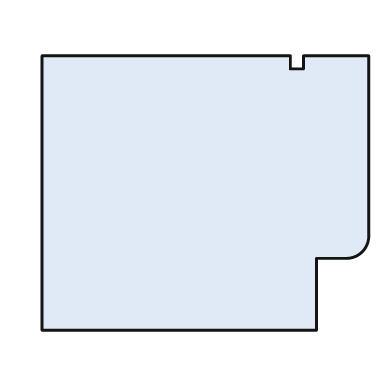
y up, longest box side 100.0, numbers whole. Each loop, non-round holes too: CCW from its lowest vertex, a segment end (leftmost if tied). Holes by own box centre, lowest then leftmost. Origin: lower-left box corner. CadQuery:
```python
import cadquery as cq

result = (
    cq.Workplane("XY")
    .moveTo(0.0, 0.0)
    .lineTo(84.0, 0.0)
    .lineTo(84.0, 22.0)
    .lineTo(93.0, 22.0)
    .threePointArc((98.0, 24.0), (100.0, 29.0))
    .lineTo(100.0, 84.0)
    .lineTo(80.0, 84.0)
    .lineTo(80.0, 80.0)
    .lineTo(76.0, 80.0)
    .lineTo(76.0, 84.0)
    .lineTo(0.0, 84.0)
    .close()
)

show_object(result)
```